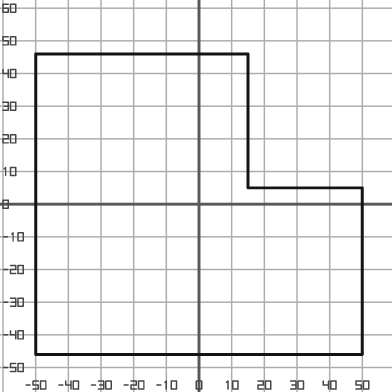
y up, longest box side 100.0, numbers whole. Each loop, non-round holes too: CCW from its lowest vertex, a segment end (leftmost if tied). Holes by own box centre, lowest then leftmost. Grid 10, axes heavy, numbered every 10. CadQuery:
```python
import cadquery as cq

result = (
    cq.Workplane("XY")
    .moveTo(-50.0, -46.0)
    .lineTo(50.0, -46.0)
    .lineTo(50.0, 5.0)
    .lineTo(15.0, 5.0)
    .lineTo(15.0, 46.0)
    .lineTo(-50.0, 46.0)
    .close()
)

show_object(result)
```